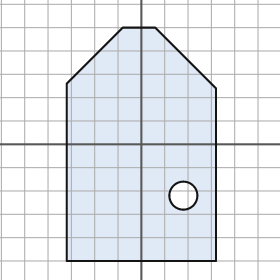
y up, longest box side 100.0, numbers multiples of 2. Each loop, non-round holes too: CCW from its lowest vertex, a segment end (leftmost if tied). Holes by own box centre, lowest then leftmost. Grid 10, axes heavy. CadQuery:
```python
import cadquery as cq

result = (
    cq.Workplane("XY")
    .moveTo(-32.0, -50.0)
    .lineTo(32.0, -50.0)
    .lineTo(32.0, 24.0)
    .lineTo(6.0, 50.0)
    .lineTo(-8.0, 50.0)
    .lineTo(-32.0, 26.0)
    .close()
    .moveTo(18.0, -22.0)
    .circle(6.0)
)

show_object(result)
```